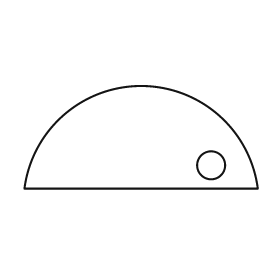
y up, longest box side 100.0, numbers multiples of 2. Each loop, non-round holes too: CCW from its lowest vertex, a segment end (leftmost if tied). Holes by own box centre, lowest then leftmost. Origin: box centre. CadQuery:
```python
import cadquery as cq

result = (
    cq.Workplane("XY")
    .moveTo(-50.0, -22.0)
    .lineTo(50.0, -22.0)
    .threePointArc((0.0, 22.0), (-50.0, -22.0))
    .close()
    .moveTo(30.0, -12.0)
    .circle(6.0)
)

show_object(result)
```